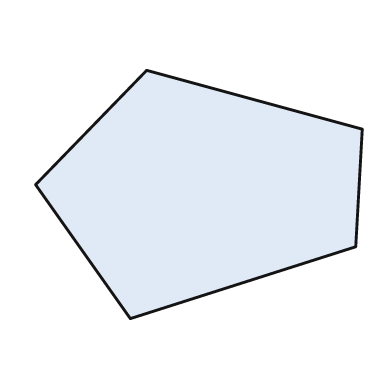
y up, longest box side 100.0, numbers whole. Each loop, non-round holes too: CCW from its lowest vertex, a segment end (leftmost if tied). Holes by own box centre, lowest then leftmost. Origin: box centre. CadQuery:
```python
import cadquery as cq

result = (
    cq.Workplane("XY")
    .moveTo(-21.0, -38.0)
    .lineTo(48.0, -16.0)
    .lineTo(50.0, 20.0)
    .lineTo(-16.0, 38.0)
    .lineTo(-50.0, 3.0)
    .close()
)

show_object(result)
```